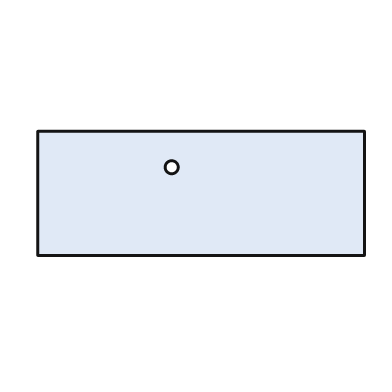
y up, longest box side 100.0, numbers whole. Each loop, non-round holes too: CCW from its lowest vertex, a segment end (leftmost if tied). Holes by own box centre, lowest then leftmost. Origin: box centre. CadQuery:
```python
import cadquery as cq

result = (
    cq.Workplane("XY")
    .moveTo(-50.0, -19.0)
    .lineTo(50.0, -19.0)
    .lineTo(50.0, 19.0)
    .lineTo(-50.0, 19.0)
    .close()
    .moveTo(-9.0, 8.0)
    .circle(2.0)
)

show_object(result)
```